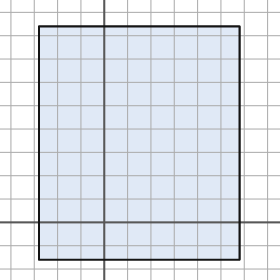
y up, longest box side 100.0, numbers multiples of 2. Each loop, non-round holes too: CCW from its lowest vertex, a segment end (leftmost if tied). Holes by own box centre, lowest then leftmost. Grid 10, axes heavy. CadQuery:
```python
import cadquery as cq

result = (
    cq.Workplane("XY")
    .moveTo(-28.0, -16.0)
    .lineTo(58.0, -16.0)
    .lineTo(58.0, 84.0)
    .lineTo(-28.0, 84.0)
    .close()
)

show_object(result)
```